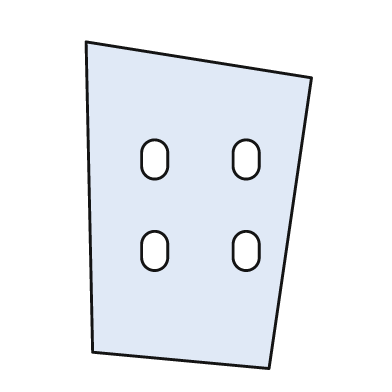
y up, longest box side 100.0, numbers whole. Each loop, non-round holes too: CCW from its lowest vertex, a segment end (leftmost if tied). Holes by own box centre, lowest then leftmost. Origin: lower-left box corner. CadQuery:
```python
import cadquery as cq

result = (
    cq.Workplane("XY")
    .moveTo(56.0, 0.0)
    .lineTo(69.0, 89.0)
    .lineTo(0.0, 100.0)
    .lineTo(2.0, 5.0)
    .close()
    .moveTo(17.0, 34.0)
    .threePointArc((21.0, 30.0), (25.0, 34.0))
    .lineTo(25.0, 38.0)
    .threePointArc((21.0, 42.0), (17.0, 38.0))
    .close()
    .moveTo(45.0, 34.0)
    .threePointArc((49.0, 30.0), (53.0, 34.0))
    .lineTo(53.0, 38.0)
    .threePointArc((49.0, 42.0), (45.0, 38.0))
    .close()
    .moveTo(17.0, 62.0)
    .threePointArc((21.0, 58.0), (25.0, 62.0))
    .lineTo(25.0, 66.0)
    .threePointArc((21.0, 70.0), (17.0, 66.0))
    .close()
    .moveTo(45.0, 62.0)
    .threePointArc((49.0, 58.0), (53.0, 62.0))
    .lineTo(53.0, 66.0)
    .threePointArc((49.0, 70.0), (45.0, 66.0))
    .close()
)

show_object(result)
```